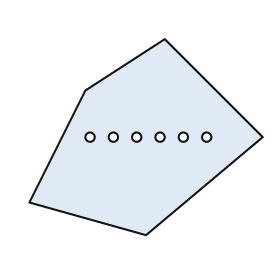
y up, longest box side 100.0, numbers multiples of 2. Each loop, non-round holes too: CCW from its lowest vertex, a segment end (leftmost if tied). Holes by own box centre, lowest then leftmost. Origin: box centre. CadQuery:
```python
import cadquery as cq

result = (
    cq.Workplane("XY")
    .moveTo(0.0, -42.0)
    .lineTo(50.0, 0.0)
    .lineTo(8.0, 42.0)
    .lineTo(-26.0, 20.0)
    .lineTo(-50.0, -28.0)
    .close()
    .moveTo(-24.0, 0.0)
    .circle(2.0)
    .moveTo(-14.0, 0.0)
    .circle(2.0)
    .moveTo(-4.0, 0.0)
    .circle(2.0)
    .moveTo(6.0, 0.0)
    .circle(2.0)
    .moveTo(16.0, 0.0)
    .circle(2.0)
    .moveTo(26.0, 0.0)
    .circle(2.0)
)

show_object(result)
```